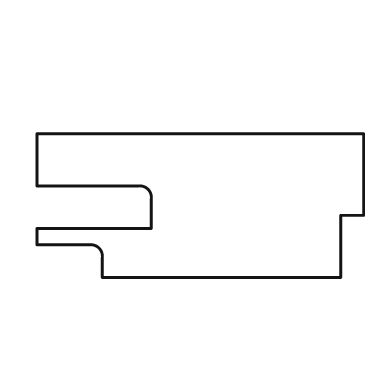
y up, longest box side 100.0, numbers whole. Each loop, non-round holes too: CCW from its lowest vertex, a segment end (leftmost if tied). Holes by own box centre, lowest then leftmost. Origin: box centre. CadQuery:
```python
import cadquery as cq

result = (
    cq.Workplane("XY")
    .moveTo(-30.0, -22.0)
    .lineTo(43.0, -22.0)
    .lineTo(43.0, -3.0)
    .lineTo(50.0, -3.0)
    .lineTo(50.0, 22.0)
    .lineTo(-50.0, 22.0)
    .lineTo(-50.0, 6.0)
    .lineTo(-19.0, 6.0)
    .threePointArc((-16.0, 5.0), (-15.0, 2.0))
    .lineTo(-15.0, -7.0)
    .lineTo(-50.0, -7.0)
    .lineTo(-50.0, -12.0)
    .lineTo(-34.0, -12.0)
    .threePointArc((-31.0, -13.0), (-30.0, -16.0))
    .close()
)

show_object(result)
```